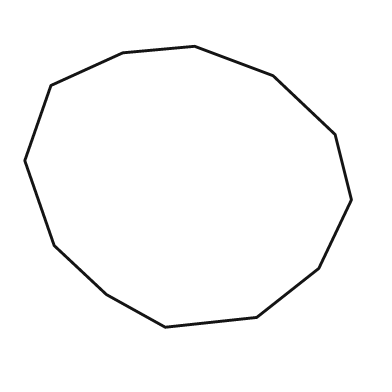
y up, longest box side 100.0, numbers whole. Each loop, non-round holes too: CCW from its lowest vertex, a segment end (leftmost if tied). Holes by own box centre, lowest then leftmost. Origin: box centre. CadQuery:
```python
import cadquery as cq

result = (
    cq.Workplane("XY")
    .moveTo(-7.0, -43.0)
    .lineTo(21.0, -40.0)
    .lineTo(40.0, -25.0)
    .lineTo(50.0, -4.0)
    .lineTo(45.0, 16.0)
    .lineTo(26.0, 34.0)
    .lineTo(2.0, 43.0)
    .lineTo(-20.0, 41.0)
    .lineTo(-42.0, 31.0)
    .lineTo(-50.0, 8.0)
    .lineTo(-41.0, -18.0)
    .lineTo(-25.0, -33.0)
    .close()
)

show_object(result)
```